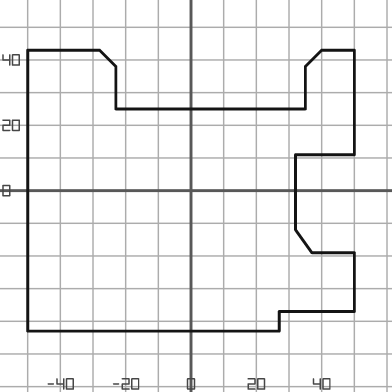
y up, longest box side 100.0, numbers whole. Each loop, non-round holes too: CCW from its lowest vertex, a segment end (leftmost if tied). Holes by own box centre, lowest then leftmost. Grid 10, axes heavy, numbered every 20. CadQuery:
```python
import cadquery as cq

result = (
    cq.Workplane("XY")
    .moveTo(-50.0, -43.0)
    .lineTo(27.0, -43.0)
    .lineTo(27.0, -37.0)
    .lineTo(50.0, -37.0)
    .lineTo(50.0, -19.0)
    .lineTo(37.0, -19.0)
    .lineTo(32.0, -12.0)
    .lineTo(32.0, 11.0)
    .lineTo(50.0, 11.0)
    .lineTo(50.0, 43.0)
    .lineTo(40.0, 43.0)
    .lineTo(35.0, 38.0)
    .lineTo(35.0, 25.0)
    .lineTo(-23.0, 25.0)
    .lineTo(-23.0, 38.0)
    .lineTo(-28.0, 43.0)
    .lineTo(-50.0, 43.0)
    .close()
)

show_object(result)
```